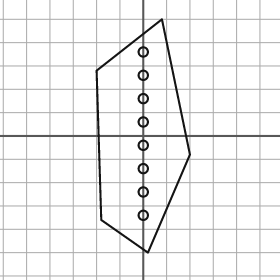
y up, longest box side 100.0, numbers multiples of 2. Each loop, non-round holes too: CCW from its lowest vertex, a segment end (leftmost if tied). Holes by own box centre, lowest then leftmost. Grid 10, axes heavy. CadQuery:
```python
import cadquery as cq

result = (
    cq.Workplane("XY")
    .moveTo(2.0, -50.0)
    .lineTo(20.0, -8.0)
    .lineTo(8.0, 50.0)
    .lineTo(-20.0, 28.0)
    .lineTo(-18.0, -36.0)
    .close()
    .moveTo(0.0, -34.0)
    .circle(2.0)
    .moveTo(0.0, -24.0)
    .circle(2.0)
    .moveTo(0.0, -14.0)
    .circle(2.0)
    .moveTo(0.0, -4.0)
    .circle(2.0)
    .moveTo(0.0, 6.0)
    .circle(2.0)
    .moveTo(0.0, 16.0)
    .circle(2.0)
    .moveTo(0.0, 26.0)
    .circle(2.0)
    .moveTo(0.0, 36.0)
    .circle(2.0)
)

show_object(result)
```